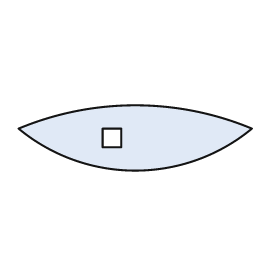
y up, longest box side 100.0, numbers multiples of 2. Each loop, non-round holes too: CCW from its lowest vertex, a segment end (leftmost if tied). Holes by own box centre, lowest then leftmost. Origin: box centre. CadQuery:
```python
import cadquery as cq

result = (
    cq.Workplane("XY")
    .moveTo(-50.0, 4.0)
    .threePointArc((0.0, -14.0), (50.0, 4.0))
    .threePointArc((0.0, 14.0), (-50.0, 4.0))
    .close()
    .moveTo(-14.0, -4.0)
    .lineTo(-6.0, -4.0)
    .lineTo(-6.0, 4.0)
    .lineTo(-14.0, 4.0)
    .close()
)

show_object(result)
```